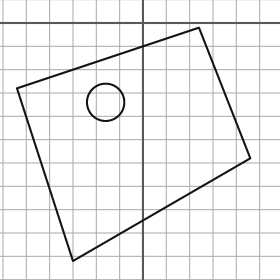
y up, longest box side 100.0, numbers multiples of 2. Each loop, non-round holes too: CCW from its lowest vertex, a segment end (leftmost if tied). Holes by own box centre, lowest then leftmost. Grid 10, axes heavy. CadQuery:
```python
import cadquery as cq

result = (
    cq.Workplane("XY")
    .moveTo(-30.0, -102.0)
    .lineTo(46.0, -58.0)
    .lineTo(24.0, -2.0)
    .lineTo(-54.0, -28.0)
    .close()
    .moveTo(-16.0, -34.0)
    .circle(8.0)
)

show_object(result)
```